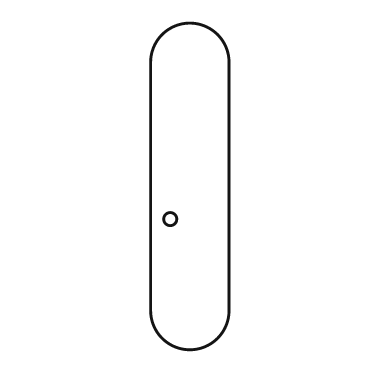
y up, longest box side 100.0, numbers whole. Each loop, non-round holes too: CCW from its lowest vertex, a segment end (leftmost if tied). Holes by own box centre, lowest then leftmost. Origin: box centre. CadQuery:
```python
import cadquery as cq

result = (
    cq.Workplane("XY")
    .moveTo(-12.0, -38.0)
    .threePointArc((0.0, -50.0), (12.0, -38.0))
    .lineTo(12.0, 38.0)
    .threePointArc((0.0, 50.0), (-12.0, 38.0))
    .close()
    .moveTo(-6.0, -10.0)
    .circle(2.0)
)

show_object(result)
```